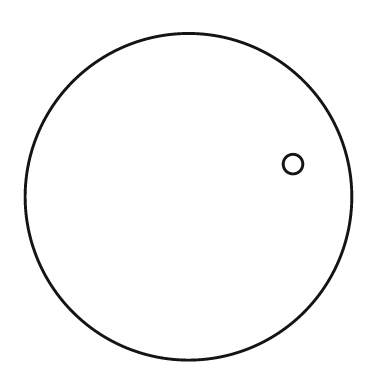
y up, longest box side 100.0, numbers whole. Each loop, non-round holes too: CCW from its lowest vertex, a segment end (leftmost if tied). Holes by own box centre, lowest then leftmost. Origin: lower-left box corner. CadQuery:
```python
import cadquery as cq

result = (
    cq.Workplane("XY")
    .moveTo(50.0, 50.0)
    .circle(50.0)
    .moveTo(82.0, 60.0)
    .circle(3.0)
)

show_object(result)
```